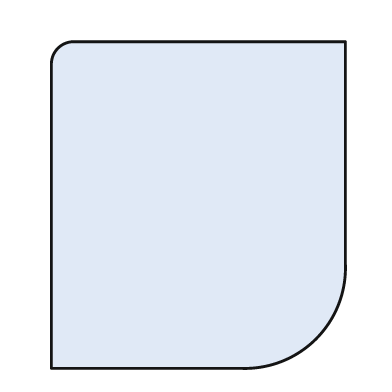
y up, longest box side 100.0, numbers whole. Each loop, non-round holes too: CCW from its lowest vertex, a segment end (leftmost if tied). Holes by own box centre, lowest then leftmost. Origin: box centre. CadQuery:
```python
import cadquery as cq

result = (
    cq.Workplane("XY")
    .moveTo(-45.0, -50.0)
    .lineTo(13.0, -50.0)
    .threePointArc((36.0, -41.0), (45.0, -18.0))
    .lineTo(45.0, 50.0)
    .lineTo(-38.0, 50.0)
    .threePointArc((-43.0, 48.0), (-45.0, 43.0))
    .close()
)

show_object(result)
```